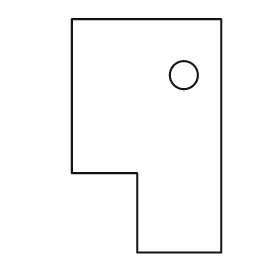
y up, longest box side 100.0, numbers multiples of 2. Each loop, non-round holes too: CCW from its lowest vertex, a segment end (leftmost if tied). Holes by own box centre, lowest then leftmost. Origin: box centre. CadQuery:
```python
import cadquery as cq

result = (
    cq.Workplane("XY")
    .moveTo(-4.0, -50.0)
    .lineTo(32.0, -50.0)
    .lineTo(32.0, 50.0)
    .lineTo(-32.0, 50.0)
    .lineTo(-32.0, -16.0)
    .lineTo(-4.0, -16.0)
    .close()
    .moveTo(16.0, 26.0)
    .circle(6.0)
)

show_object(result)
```